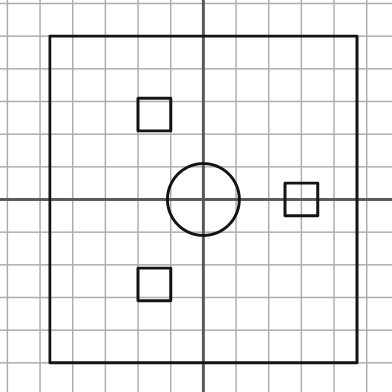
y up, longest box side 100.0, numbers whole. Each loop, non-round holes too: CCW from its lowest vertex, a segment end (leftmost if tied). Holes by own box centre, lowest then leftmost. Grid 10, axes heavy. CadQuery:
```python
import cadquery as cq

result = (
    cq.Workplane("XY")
    .moveTo(-47.0, -50.0)
    .lineTo(47.0, -50.0)
    .lineTo(47.0, 50.0)
    .lineTo(-47.0, 50.0)
    .close()
    .moveTo(-20.0, -31.0)
    .lineTo(-10.0, -31.0)
    .lineTo(-10.0, -21.0)
    .lineTo(-20.0, -21.0)
    .close()
    .moveTo(0.0, 0.0)
    .circle(11.0)
    .moveTo(25.0, -5.0)
    .lineTo(35.0, -5.0)
    .lineTo(35.0, 5.0)
    .lineTo(25.0, 5.0)
    .close()
    .moveTo(-20.0, 21.0)
    .lineTo(-10.0, 21.0)
    .lineTo(-10.0, 31.0)
    .lineTo(-20.0, 31.0)
    .close()
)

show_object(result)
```